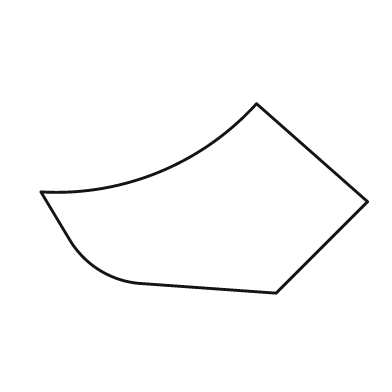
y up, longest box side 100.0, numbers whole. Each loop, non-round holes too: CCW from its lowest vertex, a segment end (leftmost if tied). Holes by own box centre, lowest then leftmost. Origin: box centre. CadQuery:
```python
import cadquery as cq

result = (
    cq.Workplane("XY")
    .moveTo(22.0, -29.0)
    .lineTo(50.0, -1.0)
    .lineTo(16.0, 29.0)
    .threePointArc((-14.0, 8.0), (-50.0, 2.0))
    .lineTo(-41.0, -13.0)
    .threePointArc((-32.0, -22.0), (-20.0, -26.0))
    .close()
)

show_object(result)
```